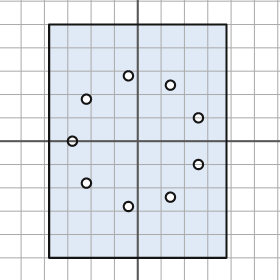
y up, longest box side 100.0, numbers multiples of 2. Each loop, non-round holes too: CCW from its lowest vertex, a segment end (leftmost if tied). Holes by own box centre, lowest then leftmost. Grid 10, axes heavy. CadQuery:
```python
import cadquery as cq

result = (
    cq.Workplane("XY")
    .moveTo(-38.0, -50.0)
    .lineTo(38.0, -50.0)
    .lineTo(38.0, 50.0)
    .lineTo(-38.0, 50.0)
    .close()
    .moveTo(-4.0, -28.0)
    .circle(2.0)
    .moveTo(14.0, -24.0)
    .circle(2.0)
    .moveTo(-22.0, -18.0)
    .circle(2.0)
    .moveTo(26.0, -10.0)
    .circle(2.0)
    .moveTo(-28.0, 0.0)
    .circle(2.0)
    .moveTo(26.0, 10.0)
    .circle(2.0)
    .moveTo(-22.0, 18.0)
    .circle(2.0)
    .moveTo(14.0, 24.0)
    .circle(2.0)
    .moveTo(-4.0, 28.0)
    .circle(2.0)
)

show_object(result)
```